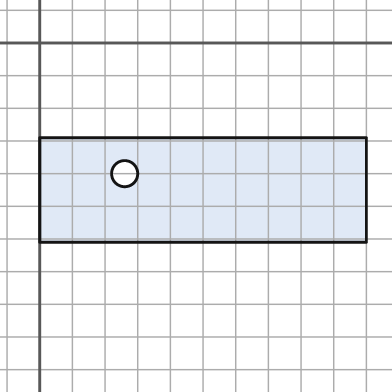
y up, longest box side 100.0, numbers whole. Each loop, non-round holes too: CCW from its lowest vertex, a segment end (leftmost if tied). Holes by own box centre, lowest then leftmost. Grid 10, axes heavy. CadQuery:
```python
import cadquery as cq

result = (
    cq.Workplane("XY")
    .moveTo(0.0, -61.0)
    .lineTo(100.0, -61.0)
    .lineTo(100.0, -29.0)
    .lineTo(0.0, -29.0)
    .close()
    .moveTo(26.0, -40.0)
    .circle(4.0)
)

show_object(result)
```